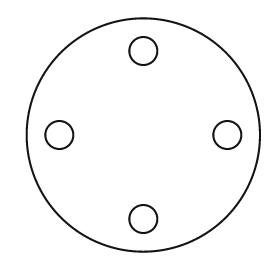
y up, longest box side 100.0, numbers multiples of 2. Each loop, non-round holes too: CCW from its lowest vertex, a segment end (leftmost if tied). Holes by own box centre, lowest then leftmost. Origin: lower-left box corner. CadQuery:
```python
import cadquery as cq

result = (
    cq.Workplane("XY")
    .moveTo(50.0, 50.0)
    .circle(50.0)
    .moveTo(50.0, 14.0)
    .circle(6.0)
    .moveTo(14.0, 50.0)
    .circle(6.0)
    .moveTo(86.0, 50.0)
    .circle(6.0)
    .moveTo(50.0, 86.0)
    .circle(6.0)
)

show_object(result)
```